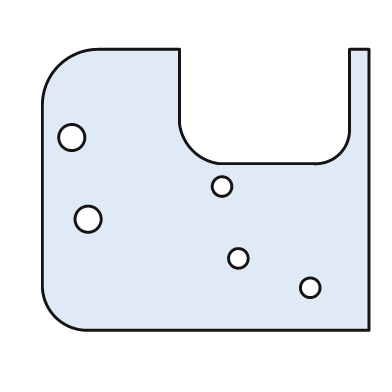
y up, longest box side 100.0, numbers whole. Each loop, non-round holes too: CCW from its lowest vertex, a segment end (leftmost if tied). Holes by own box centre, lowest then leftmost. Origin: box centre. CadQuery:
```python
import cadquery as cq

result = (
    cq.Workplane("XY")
    .moveTo(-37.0, -43.0)
    .lineTo(50.0, -43.0)
    .lineTo(50.0, 43.0)
    .lineTo(44.0, 43.0)
    .lineTo(44.0, 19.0)
    .threePointArc((41.0, 11.0), (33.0, 8.0))
    .lineTo(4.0, 8.0)
    .threePointArc((-4.0, 12.0), (-8.0, 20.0))
    .lineTo(-8.0, 43.0)
    .lineTo(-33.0, 43.0)
    .threePointArc((-45.0, 38.0), (-50.0, 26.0))
    .lineTo(-50.0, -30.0)
    .threePointArc((-46.0, -39.0), (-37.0, -43.0))
    .close()
    .moveTo(32.0, -30.0)
    .circle(3.0)
    .moveTo(10.0, -21.0)
    .circle(3.0)
    .moveTo(-36.0, -9.0)
    .circle(4.0)
    .moveTo(5.0, 1.0)
    .circle(3.0)
    .moveTo(-41.0, 16.0)
    .circle(4.0)
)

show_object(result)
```